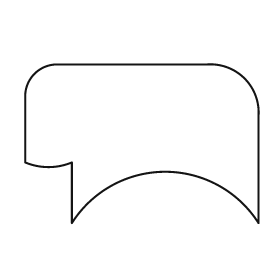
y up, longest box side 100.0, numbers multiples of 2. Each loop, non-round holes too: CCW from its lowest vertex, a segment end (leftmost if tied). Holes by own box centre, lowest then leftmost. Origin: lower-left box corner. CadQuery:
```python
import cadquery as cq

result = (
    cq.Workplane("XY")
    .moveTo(20.0, 0.0)
    .threePointArc((60.0, 22.0), (100.0, 0.0))
    .lineTo(100.0, 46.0)
    .threePointArc((94.0, 62.0), (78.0, 68.0))
    .lineTo(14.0, 68.0)
    .threePointArc((4.0, 64.0), (0.0, 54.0))
    .lineTo(0.0, 26.0)
    .threePointArc((10.0, 24.0), (20.0, 26.0))
    .close()
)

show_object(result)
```